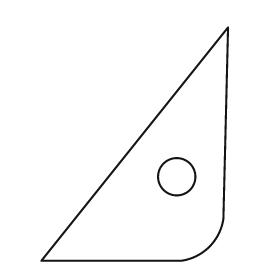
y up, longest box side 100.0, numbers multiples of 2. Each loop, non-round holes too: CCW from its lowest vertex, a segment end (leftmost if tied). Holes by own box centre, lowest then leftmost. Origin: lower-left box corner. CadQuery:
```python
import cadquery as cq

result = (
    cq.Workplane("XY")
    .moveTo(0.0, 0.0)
    .lineTo(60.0, 0.0)
    .threePointArc((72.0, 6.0), (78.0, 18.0))
    .lineTo(80.0, 100.0)
    .close()
    .moveTo(58.0, 36.0)
    .circle(8.0)
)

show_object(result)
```